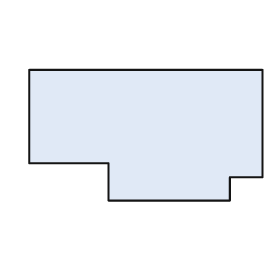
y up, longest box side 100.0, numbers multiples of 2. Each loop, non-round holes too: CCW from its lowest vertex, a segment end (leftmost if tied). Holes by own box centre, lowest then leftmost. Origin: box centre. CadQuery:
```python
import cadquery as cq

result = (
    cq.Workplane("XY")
    .moveTo(-16.0, -28.0)
    .lineTo(36.0, -28.0)
    .lineTo(36.0, -18.0)
    .lineTo(50.0, -18.0)
    .lineTo(50.0, 28.0)
    .lineTo(-50.0, 28.0)
    .lineTo(-50.0, -12.0)
    .lineTo(-16.0, -12.0)
    .close()
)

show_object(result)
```